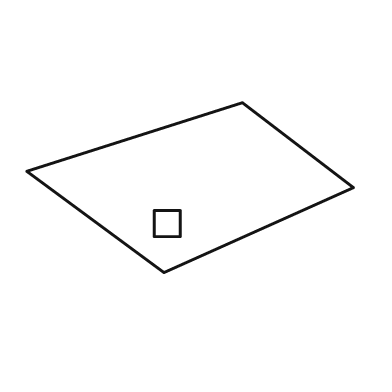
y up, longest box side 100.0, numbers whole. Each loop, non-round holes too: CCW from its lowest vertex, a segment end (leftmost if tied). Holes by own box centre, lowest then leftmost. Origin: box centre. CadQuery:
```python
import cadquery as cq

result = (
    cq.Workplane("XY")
    .moveTo(-8.0, -26.0)
    .lineTo(50.0, 0.0)
    .lineTo(16.0, 26.0)
    .lineTo(-50.0, 5.0)
    .close()
    .moveTo(-11.0, -15.0)
    .lineTo(-3.0, -15.0)
    .lineTo(-3.0, -7.0)
    .lineTo(-11.0, -7.0)
    .close()
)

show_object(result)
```